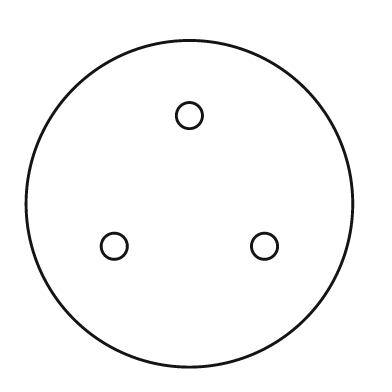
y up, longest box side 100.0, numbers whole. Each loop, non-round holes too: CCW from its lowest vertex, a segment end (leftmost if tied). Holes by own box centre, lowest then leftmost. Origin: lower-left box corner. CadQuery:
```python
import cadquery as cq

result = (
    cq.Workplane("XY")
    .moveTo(50.0, 50.0)
    .circle(50.0)
    .moveTo(27.0, 37.0)
    .circle(4.0)
    .moveTo(73.0, 37.0)
    .circle(4.0)
    .moveTo(50.0, 77.0)
    .circle(4.0)
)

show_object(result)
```